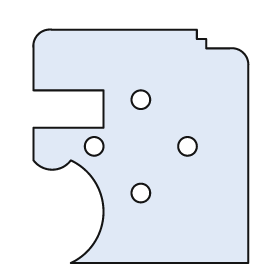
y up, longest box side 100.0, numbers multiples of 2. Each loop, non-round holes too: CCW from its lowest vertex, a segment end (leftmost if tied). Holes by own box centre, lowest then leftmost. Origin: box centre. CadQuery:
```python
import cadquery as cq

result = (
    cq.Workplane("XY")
    .moveTo(-30.0, -50.0)
    .lineTo(46.0, -50.0)
    .lineTo(46.0, 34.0)
    .threePointArc((44.0, 40.0), (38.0, 42.0))
    .lineTo(28.0, 42.0)
    .lineTo(28.0, 46.0)
    .lineTo(24.0, 46.0)
    .lineTo(24.0, 50.0)
    .lineTo(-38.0, 50.0)
    .threePointArc((-44.0, 48.0), (-46.0, 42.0))
    .lineTo(-46.0, 24.0)
    .lineTo(-16.0, 24.0)
    .lineTo(-16.0, 8.0)
    .lineTo(-46.0, 8.0)
    .lineTo(-46.0, -6.0)
    .threePointArc((-38.0, -10.0), (-30.0, -6.0))
    .threePointArc((-16.0, -28.0), (-30.0, -50.0))
    .close()
    .moveTo(0.0, -20.0)
    .circle(4.0)
    .moveTo(-20.0, 0.0)
    .circle(4.0)
    .moveTo(20.0, 0.0)
    .circle(4.0)
    .moveTo(0.0, 20.0)
    .circle(4.0)
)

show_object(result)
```